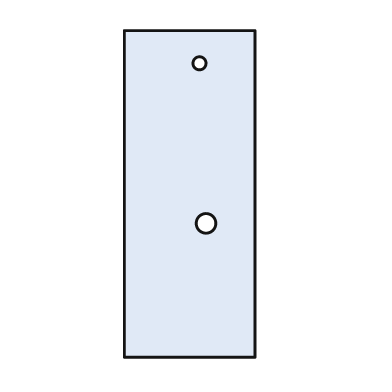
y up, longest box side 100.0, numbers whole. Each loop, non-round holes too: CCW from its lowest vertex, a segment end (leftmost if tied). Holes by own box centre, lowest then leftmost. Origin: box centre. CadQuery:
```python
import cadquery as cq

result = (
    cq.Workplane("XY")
    .moveTo(-20.0, -50.0)
    .lineTo(20.0, -50.0)
    .lineTo(20.0, 50.0)
    .lineTo(-20.0, 50.0)
    .close()
    .moveTo(5.0, -9.0)
    .circle(3.0)
    .moveTo(3.0, 40.0)
    .circle(2.0)
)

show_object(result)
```